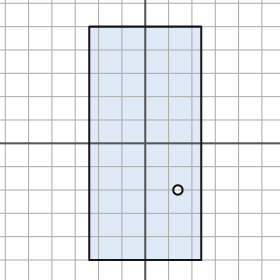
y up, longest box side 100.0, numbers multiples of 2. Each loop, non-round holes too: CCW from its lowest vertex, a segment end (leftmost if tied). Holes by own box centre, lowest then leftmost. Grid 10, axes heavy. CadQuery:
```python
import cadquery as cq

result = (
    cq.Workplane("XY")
    .moveTo(-24.0, -50.0)
    .lineTo(24.0, -50.0)
    .lineTo(24.0, 50.0)
    .lineTo(-24.0, 50.0)
    .close()
    .moveTo(14.0, -20.0)
    .circle(2.0)
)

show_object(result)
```